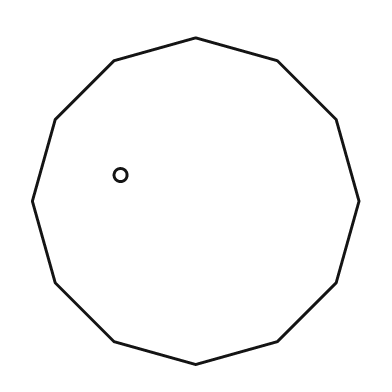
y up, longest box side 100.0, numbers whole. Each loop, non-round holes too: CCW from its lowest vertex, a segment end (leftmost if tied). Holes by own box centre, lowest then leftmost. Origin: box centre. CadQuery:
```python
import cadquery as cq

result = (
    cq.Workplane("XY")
    .moveTo(0.0, -50.0)
    .lineTo(25.0, -43.0)
    .lineTo(43.0, -25.0)
    .lineTo(50.0, 0.0)
    .lineTo(43.0, 25.0)
    .lineTo(25.0, 43.0)
    .lineTo(0.0, 50.0)
    .lineTo(-25.0, 43.0)
    .lineTo(-43.0, 25.0)
    .lineTo(-50.0, 0.0)
    .lineTo(-43.0, -25.0)
    .lineTo(-25.0, -43.0)
    .close()
    .moveTo(-23.0, 8.0)
    .circle(2.0)
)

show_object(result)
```